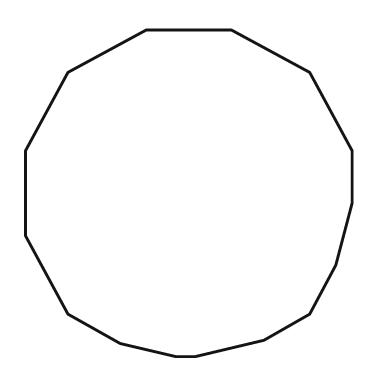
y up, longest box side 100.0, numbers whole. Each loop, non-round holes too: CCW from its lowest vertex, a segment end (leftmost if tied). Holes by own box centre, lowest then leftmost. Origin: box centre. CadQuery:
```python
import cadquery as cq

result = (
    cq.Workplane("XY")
    .moveTo(-4.0, -50.0)
    .lineTo(2.0, -50.0)
    .lineTo(23.0, -45.0)
    .lineTo(37.0, -37.0)
    .lineTo(45.0, -22.0)
    .lineTo(50.0, -3.0)
    .lineTo(50.0, 13.0)
    .lineTo(37.0, 37.0)
    .lineTo(13.0, 50.0)
    .lineTo(-13.0, 50.0)
    .lineTo(-37.0, 37.0)
    .lineTo(-50.0, 13.0)
    .lineTo(-50.0, -13.0)
    .lineTo(-37.0, -37.0)
    .lineTo(-21.0, -46.0)
    .close()
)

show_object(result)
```